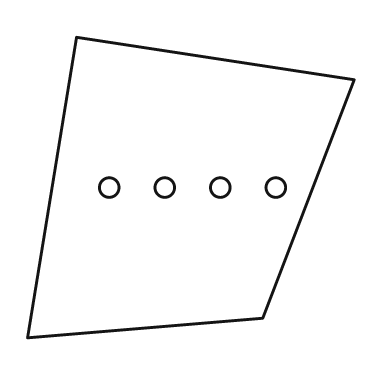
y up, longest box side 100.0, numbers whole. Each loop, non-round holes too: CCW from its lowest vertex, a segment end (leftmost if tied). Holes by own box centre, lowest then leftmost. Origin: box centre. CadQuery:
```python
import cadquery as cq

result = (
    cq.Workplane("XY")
    .moveTo(-50.0, -46.0)
    .lineTo(22.0, -40.0)
    .lineTo(50.0, 33.0)
    .lineTo(-35.0, 46.0)
    .close()
    .moveTo(-25.0, 0.0)
    .circle(3.0)
    .moveTo(-8.0, 0.0)
    .circle(3.0)
    .moveTo(9.0, 0.0)
    .circle(3.0)
    .moveTo(26.0, 0.0)
    .circle(3.0)
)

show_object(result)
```